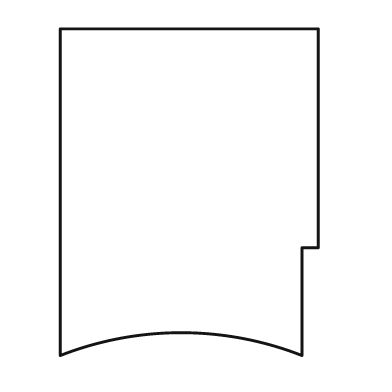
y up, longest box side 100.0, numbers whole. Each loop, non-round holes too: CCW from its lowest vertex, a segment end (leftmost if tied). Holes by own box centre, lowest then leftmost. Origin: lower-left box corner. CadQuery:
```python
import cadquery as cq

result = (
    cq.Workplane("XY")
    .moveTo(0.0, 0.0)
    .threePointArc((37.0, 7.0), (74.0, 0.0))
    .lineTo(74.0, 33.0)
    .lineTo(79.0, 33.0)
    .lineTo(79.0, 100.0)
    .lineTo(0.0, 100.0)
    .close()
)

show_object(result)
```